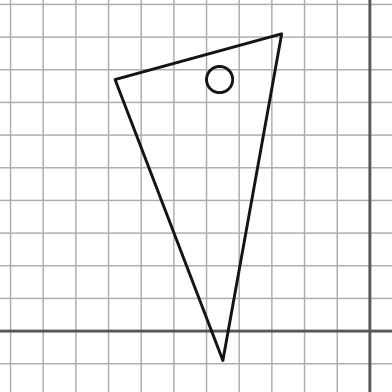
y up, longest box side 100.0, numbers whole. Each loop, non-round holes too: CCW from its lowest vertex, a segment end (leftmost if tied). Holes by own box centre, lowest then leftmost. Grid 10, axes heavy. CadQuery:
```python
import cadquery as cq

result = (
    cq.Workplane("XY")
    .moveTo(-45.0, -9.0)
    .lineTo(-27.0, 91.0)
    .lineTo(-78.0, 77.0)
    .close()
    .moveTo(-46.0, 77.0)
    .circle(4.0)
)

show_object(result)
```